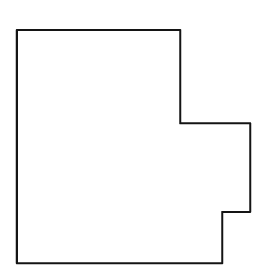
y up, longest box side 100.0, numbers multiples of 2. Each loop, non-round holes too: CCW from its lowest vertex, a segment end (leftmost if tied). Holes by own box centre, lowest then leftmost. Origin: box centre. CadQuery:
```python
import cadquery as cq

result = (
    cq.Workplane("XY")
    .moveTo(-50.0, -50.0)
    .lineTo(38.0, -50.0)
    .lineTo(38.0, -28.0)
    .lineTo(50.0, -28.0)
    .lineTo(50.0, 10.0)
    .lineTo(20.0, 10.0)
    .lineTo(20.0, 50.0)
    .lineTo(-50.0, 50.0)
    .close()
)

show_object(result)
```